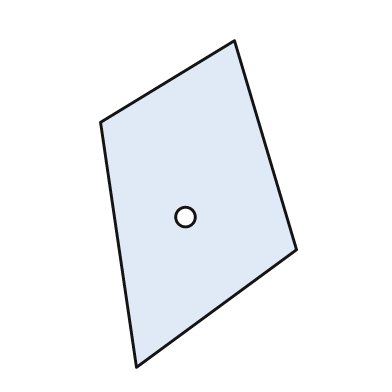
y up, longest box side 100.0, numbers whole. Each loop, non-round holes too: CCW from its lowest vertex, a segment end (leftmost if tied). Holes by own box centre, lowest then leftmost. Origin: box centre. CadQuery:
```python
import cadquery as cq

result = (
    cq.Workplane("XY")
    .moveTo(-19.0, -50.0)
    .lineTo(30.0, -14.0)
    .lineTo(11.0, 50.0)
    .lineTo(-30.0, 25.0)
    .close()
    .moveTo(-4.0, -4.0)
    .circle(3.0)
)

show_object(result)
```